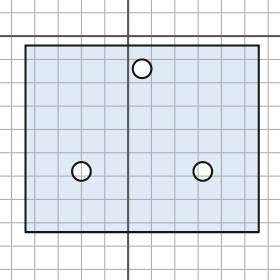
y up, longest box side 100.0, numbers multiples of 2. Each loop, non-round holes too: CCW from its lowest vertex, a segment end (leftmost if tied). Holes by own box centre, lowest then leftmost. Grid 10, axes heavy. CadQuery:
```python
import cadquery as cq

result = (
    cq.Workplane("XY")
    .moveTo(-44.0, -84.0)
    .lineTo(56.0, -84.0)
    .lineTo(56.0, -4.0)
    .lineTo(-44.0, -4.0)
    .close()
    .moveTo(-20.0, -58.0)
    .circle(4.0)
    .moveTo(32.0, -58.0)
    .circle(4.0)
    .moveTo(6.0, -14.0)
    .circle(4.0)
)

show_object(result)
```